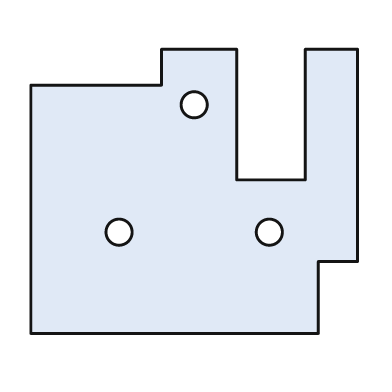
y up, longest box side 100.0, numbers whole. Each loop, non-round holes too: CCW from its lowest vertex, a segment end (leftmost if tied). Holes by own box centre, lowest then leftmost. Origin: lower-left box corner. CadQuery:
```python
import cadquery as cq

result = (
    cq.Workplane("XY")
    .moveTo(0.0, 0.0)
    .lineTo(88.0, 0.0)
    .lineTo(88.0, 22.0)
    .lineTo(100.0, 22.0)
    .lineTo(100.0, 87.0)
    .lineTo(84.0, 87.0)
    .lineTo(84.0, 47.0)
    .lineTo(63.0, 47.0)
    .lineTo(63.0, 87.0)
    .lineTo(40.0, 87.0)
    .lineTo(40.0, 76.0)
    .lineTo(0.0, 76.0)
    .close()
    .moveTo(27.0, 31.0)
    .circle(4.0)
    .moveTo(73.0, 31.0)
    .circle(4.0)
    .moveTo(50.0, 70.0)
    .circle(4.0)
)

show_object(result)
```